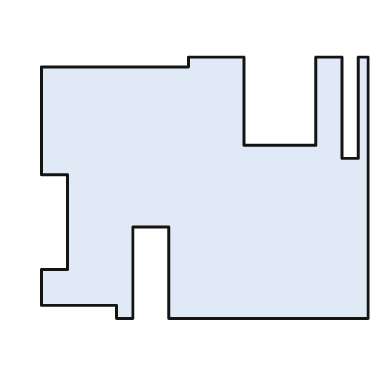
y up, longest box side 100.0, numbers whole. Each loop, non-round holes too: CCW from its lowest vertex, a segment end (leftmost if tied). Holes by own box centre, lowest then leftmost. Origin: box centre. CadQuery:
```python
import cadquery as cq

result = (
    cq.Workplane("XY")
    .moveTo(-27.0, -40.0)
    .lineTo(-22.0, -40.0)
    .lineTo(-22.0, -12.0)
    .lineTo(-11.0, -12.0)
    .lineTo(-11.0, -40.0)
    .lineTo(50.0, -40.0)
    .lineTo(50.0, 40.0)
    .lineTo(47.0, 40.0)
    .lineTo(47.0, 9.0)
    .lineTo(42.0, 9.0)
    .lineTo(42.0, 40.0)
    .lineTo(34.0, 40.0)
    .lineTo(34.0, 13.0)
    .lineTo(12.0, 13.0)
    .lineTo(12.0, 40.0)
    .lineTo(-5.0, 40.0)
    .lineTo(-5.0, 37.0)
    .lineTo(-50.0, 37.0)
    .lineTo(-50.0, 4.0)
    .lineTo(-42.0, 4.0)
    .lineTo(-42.0, -25.0)
    .lineTo(-50.0, -25.0)
    .lineTo(-50.0, -36.0)
    .lineTo(-27.0, -36.0)
    .close()
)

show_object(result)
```